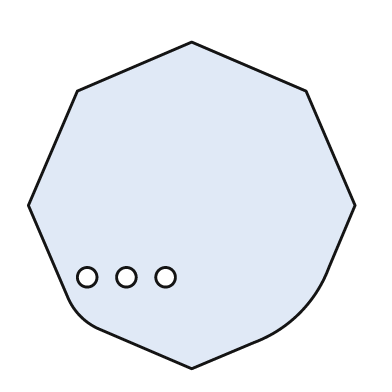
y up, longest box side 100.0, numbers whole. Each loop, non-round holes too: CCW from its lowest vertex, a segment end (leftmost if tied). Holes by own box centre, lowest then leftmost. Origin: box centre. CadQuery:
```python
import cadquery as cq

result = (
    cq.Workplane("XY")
    .moveTo(0.0, -50.0)
    .lineTo(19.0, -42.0)
    .threePointArc((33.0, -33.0), (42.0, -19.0))
    .lineTo(50.0, 0.0)
    .lineTo(35.0, 35.0)
    .lineTo(0.0, 50.0)
    .lineTo(-35.0, 35.0)
    .lineTo(-50.0, 0.0)
    .lineTo(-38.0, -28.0)
    .threePointArc((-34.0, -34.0), (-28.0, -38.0))
    .close()
    .moveTo(-32.0, -22.0)
    .circle(3.0)
    .moveTo(-20.0, -22.0)
    .circle(3.0)
    .moveTo(-8.0, -22.0)
    .circle(3.0)
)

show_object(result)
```